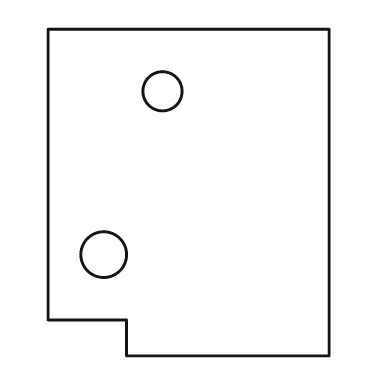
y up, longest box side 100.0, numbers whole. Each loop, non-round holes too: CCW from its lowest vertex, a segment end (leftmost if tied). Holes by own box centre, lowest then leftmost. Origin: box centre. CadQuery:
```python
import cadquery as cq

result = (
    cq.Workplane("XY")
    .moveTo(-19.0, -50.0)
    .lineTo(43.0, -50.0)
    .lineTo(43.0, 50.0)
    .lineTo(-43.0, 50.0)
    .lineTo(-43.0, -39.0)
    .lineTo(-19.0, -39.0)
    .close()
    .moveTo(-26.0, -19.0)
    .circle(7.0)
    .moveTo(-8.0, 31.0)
    .circle(6.0)
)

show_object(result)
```